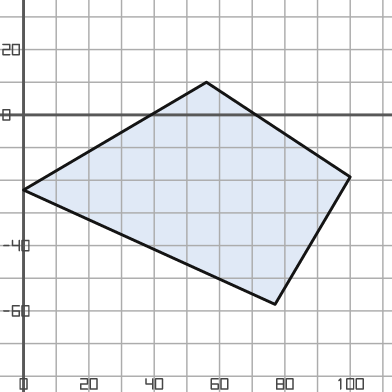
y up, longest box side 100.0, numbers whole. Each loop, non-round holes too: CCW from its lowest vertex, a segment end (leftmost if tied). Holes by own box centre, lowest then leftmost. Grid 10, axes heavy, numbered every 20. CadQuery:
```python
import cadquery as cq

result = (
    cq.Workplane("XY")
    .moveTo(77.0, -58.0)
    .lineTo(100.0, -19.0)
    .lineTo(56.0, 10.0)
    .lineTo(0.0, -23.0)
    .close()
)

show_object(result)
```